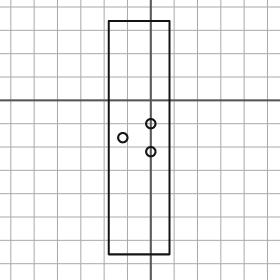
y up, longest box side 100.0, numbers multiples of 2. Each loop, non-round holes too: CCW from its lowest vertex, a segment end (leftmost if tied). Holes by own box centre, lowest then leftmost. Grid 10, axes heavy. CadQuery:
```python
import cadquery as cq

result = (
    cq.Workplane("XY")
    .moveTo(-18.0, -66.0)
    .lineTo(8.0, -66.0)
    .lineTo(8.0, 34.0)
    .lineTo(-18.0, 34.0)
    .close()
    .moveTo(0.0, -22.0)
    .circle(2.0)
    .moveTo(-12.0, -16.0)
    .circle(2.0)
    .moveTo(0.0, -10.0)
    .circle(2.0)
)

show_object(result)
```